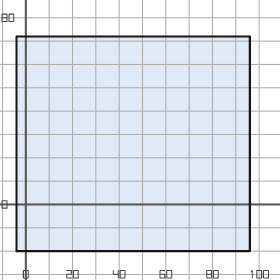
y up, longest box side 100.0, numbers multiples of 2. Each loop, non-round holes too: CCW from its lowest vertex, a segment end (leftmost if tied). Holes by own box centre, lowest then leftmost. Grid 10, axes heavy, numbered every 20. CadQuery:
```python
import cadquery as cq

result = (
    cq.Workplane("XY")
    .moveTo(-4.0, -20.0)
    .lineTo(96.0, -20.0)
    .lineTo(96.0, 72.0)
    .lineTo(-4.0, 72.0)
    .close()
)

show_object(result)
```